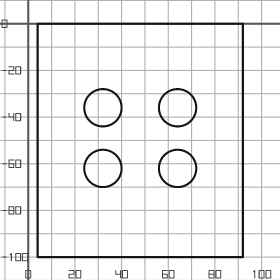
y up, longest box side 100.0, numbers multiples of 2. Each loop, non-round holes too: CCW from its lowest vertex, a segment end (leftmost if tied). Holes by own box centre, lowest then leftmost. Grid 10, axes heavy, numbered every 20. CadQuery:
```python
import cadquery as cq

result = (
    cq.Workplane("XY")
    .moveTo(4.0, -100.0)
    .lineTo(92.0, -100.0)
    .lineTo(92.0, 0.0)
    .lineTo(4.0, 0.0)
    .close()
    .moveTo(32.0, -62.0)
    .circle(8.0)
    .moveTo(64.0, -62.0)
    .circle(8.0)
    .moveTo(32.0, -36.0)
    .circle(8.0)
    .moveTo(64.0, -36.0)
    .circle(8.0)
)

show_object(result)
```